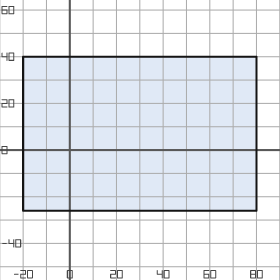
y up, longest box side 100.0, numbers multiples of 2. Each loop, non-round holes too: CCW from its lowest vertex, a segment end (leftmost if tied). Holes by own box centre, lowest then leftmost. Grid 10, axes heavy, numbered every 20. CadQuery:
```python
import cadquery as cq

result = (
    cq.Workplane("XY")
    .moveTo(-20.0, -26.0)
    .lineTo(80.0, -26.0)
    .lineTo(80.0, 40.0)
    .lineTo(-20.0, 40.0)
    .close()
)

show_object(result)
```